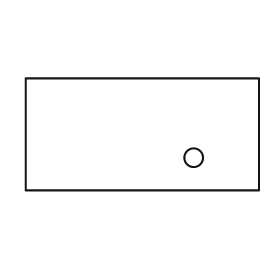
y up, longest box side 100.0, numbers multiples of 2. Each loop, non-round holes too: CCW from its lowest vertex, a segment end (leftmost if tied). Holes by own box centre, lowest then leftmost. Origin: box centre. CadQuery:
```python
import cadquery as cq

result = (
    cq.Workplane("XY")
    .moveTo(-50.0, -24.0)
    .lineTo(50.0, -24.0)
    .lineTo(50.0, 24.0)
    .lineTo(-50.0, 24.0)
    .close()
    .moveTo(22.0, -10.0)
    .circle(4.0)
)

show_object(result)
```